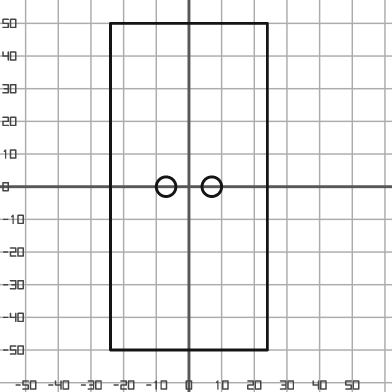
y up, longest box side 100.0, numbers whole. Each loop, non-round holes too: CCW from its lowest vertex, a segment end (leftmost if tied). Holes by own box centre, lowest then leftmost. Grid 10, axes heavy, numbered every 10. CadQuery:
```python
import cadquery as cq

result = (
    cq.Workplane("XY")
    .moveTo(-24.0, -50.0)
    .lineTo(24.0, -50.0)
    .lineTo(24.0, 50.0)
    .lineTo(-24.0, 50.0)
    .close()
    .moveTo(-7.0, 0.0)
    .circle(3.0)
    .moveTo(7.0, 0.0)
    .circle(3.0)
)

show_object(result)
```